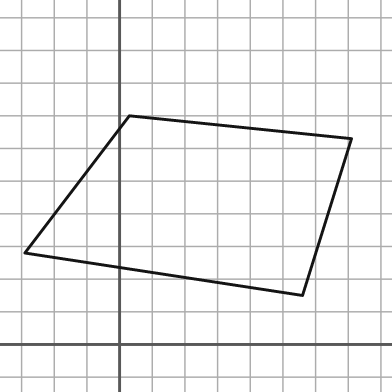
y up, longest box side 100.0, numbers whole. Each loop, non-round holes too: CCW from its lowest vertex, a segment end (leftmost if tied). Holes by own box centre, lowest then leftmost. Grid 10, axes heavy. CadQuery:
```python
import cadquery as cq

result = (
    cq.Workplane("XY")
    .moveTo(56.0, 15.0)
    .lineTo(71.0, 63.0)
    .lineTo(3.0, 70.0)
    .lineTo(-29.0, 28.0)
    .close()
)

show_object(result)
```